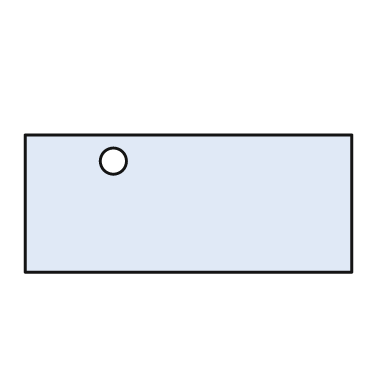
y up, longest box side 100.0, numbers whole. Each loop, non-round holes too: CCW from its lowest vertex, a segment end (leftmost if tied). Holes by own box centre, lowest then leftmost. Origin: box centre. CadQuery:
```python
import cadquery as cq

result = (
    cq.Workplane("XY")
    .moveTo(-50.0, -21.0)
    .lineTo(50.0, -21.0)
    .lineTo(50.0, 21.0)
    .lineTo(-50.0, 21.0)
    .close()
    .moveTo(-23.0, 13.0)
    .circle(4.0)
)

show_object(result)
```